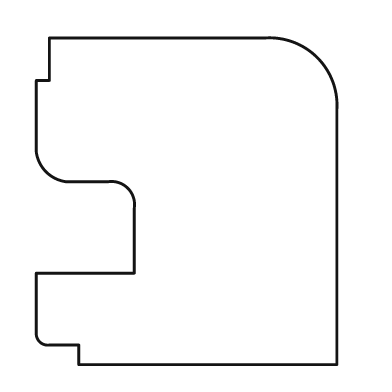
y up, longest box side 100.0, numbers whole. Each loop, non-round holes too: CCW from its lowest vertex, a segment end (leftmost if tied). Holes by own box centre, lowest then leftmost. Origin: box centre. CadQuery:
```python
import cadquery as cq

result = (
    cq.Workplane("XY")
    .moveTo(-33.0, -50.0)
    .lineTo(46.0, -50.0)
    .lineTo(46.0, 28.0)
    .threePointArc((40.0, 44.0), (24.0, 50.0))
    .lineTo(-42.0, 50.0)
    .lineTo(-42.0, 37.0)
    .lineTo(-46.0, 37.0)
    .lineTo(-46.0, 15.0)
    .threePointArc((-43.0, 9.0), (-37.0, 6.0))
    .lineTo(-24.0, 6.0)
    .threePointArc((-18.0, 4.0), (-16.0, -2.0))
    .lineTo(-16.0, -22.0)
    .lineTo(-46.0, -22.0)
    .lineTo(-46.0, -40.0)
    .threePointArc((-45.0, -43.0), (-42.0, -44.0))
    .lineTo(-33.0, -44.0)
    .close()
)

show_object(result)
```